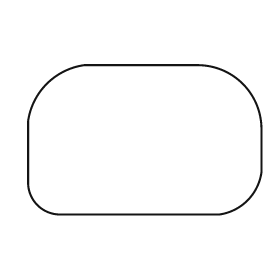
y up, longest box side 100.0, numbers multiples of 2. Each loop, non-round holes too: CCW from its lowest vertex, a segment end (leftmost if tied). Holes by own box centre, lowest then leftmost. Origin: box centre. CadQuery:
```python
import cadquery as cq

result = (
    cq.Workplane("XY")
    .moveTo(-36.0, -32.0)
    .lineTo(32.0, -32.0)
    .threePointArc((44.0, -26.0), (50.0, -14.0))
    .lineTo(50.0, 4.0)
    .threePointArc((42.0, 24.0), (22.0, 32.0))
    .lineTo(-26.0, 32.0)
    .threePointArc((-42.0, 24.0), (-50.0, 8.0))
    .lineTo(-50.0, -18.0)
    .threePointArc((-46.0, -28.0), (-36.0, -32.0))
    .close()
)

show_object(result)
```